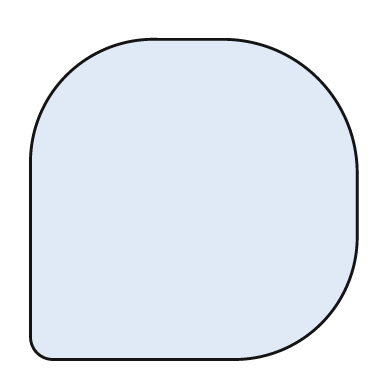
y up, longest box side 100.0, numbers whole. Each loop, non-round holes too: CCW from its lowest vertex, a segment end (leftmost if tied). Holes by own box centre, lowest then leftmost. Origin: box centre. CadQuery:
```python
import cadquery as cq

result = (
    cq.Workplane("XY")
    .moveTo(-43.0, -49.0)
    .lineTo(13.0, -49.0)
    .threePointArc((39.0, -38.0), (50.0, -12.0))
    .lineTo(50.0, 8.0)
    .threePointArc((38.0, 37.0), (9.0, 49.0))
    .lineTo(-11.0, 49.0)
    .threePointArc((-39.0, 38.0), (-50.0, 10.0))
    .lineTo(-50.0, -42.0)
    .threePointArc((-48.0, -47.0), (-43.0, -49.0))
    .close()
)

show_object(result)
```